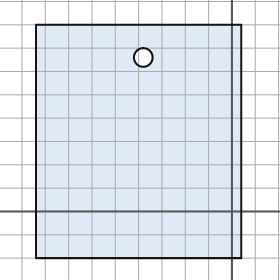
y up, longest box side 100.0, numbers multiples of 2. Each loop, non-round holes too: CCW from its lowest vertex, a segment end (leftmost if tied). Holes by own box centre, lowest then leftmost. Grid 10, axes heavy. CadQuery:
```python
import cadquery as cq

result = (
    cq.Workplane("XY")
    .moveTo(-84.0, -20.0)
    .lineTo(4.0, -20.0)
    .lineTo(4.0, 80.0)
    .lineTo(-84.0, 80.0)
    .close()
    .moveTo(-38.0, 66.0)
    .circle(4.0)
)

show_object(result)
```